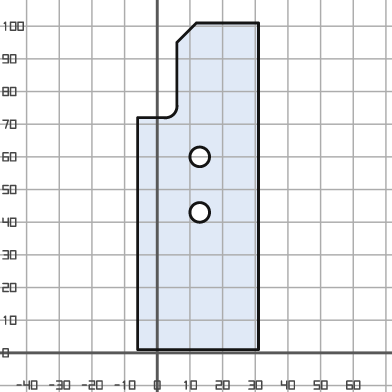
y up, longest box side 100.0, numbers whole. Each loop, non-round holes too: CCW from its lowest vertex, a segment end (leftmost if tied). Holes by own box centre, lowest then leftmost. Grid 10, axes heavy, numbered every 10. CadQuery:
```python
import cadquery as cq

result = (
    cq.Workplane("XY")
    .moveTo(-6.0, 1.0)
    .lineTo(31.0, 1.0)
    .lineTo(31.0, 101.0)
    .lineTo(12.0, 101.0)
    .lineTo(6.0, 95.0)
    .lineTo(6.0, 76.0)
    .threePointArc((5.0, 73.0), (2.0, 72.0))
    .lineTo(-6.0, 72.0)
    .close()
    .moveTo(13.0, 43.0)
    .circle(3.0)
    .moveTo(13.0, 60.0)
    .circle(3.0)
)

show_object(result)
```